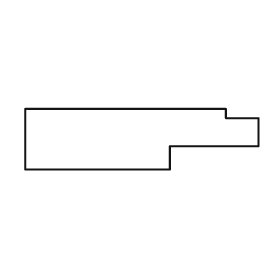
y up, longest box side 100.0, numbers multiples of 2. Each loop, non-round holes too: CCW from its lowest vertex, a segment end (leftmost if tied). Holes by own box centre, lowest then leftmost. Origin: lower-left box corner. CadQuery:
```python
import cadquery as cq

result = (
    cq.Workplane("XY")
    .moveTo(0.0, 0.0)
    .lineTo(62.0, 0.0)
    .lineTo(62.0, 10.0)
    .lineTo(100.0, 10.0)
    .lineTo(100.0, 22.0)
    .lineTo(86.0, 22.0)
    .lineTo(86.0, 26.0)
    .lineTo(0.0, 26.0)
    .close()
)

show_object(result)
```